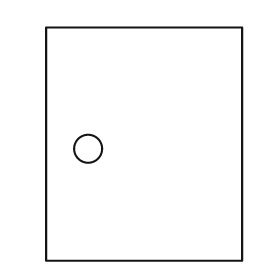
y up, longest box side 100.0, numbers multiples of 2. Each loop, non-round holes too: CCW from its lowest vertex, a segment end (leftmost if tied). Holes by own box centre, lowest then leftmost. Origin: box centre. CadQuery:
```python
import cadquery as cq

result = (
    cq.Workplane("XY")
    .moveTo(-42.0, -50.0)
    .lineTo(42.0, -50.0)
    .lineTo(42.0, 50.0)
    .lineTo(-42.0, 50.0)
    .close()
    .moveTo(-24.0, -2.0)
    .circle(6.0)
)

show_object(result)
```